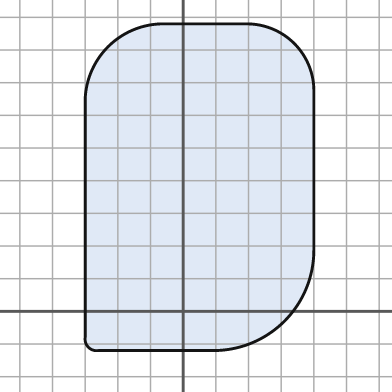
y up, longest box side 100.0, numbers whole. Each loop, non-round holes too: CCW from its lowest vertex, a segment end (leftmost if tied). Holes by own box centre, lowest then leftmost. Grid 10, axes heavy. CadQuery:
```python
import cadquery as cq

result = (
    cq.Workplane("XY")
    .moveTo(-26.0, -12.0)
    .lineTo(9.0, -12.0)
    .threePointArc((31.0, -3.0), (40.0, 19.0))
    .lineTo(40.0, 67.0)
    .threePointArc((34.0, 82.0), (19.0, 88.0))
    .lineTo(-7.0, 88.0)
    .threePointArc((-23.0, 81.0), (-30.0, 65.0))
    .lineTo(-30.0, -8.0)
    .threePointArc((-29.0, -11.0), (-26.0, -12.0))
    .close()
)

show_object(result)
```